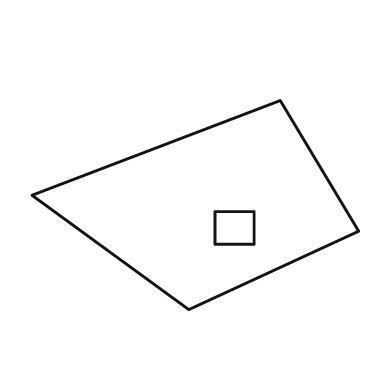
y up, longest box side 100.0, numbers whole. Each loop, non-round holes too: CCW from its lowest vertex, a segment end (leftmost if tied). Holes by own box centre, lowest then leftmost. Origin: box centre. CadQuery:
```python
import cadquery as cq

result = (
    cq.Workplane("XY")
    .moveTo(-2.0, -32.0)
    .lineTo(50.0, -8.0)
    .lineTo(26.0, 32.0)
    .lineTo(-50.0, 3.0)
    .close()
    .moveTo(6.0, -12.0)
    .lineTo(18.0, -12.0)
    .lineTo(18.0, -2.0)
    .lineTo(6.0, -2.0)
    .close()
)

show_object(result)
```